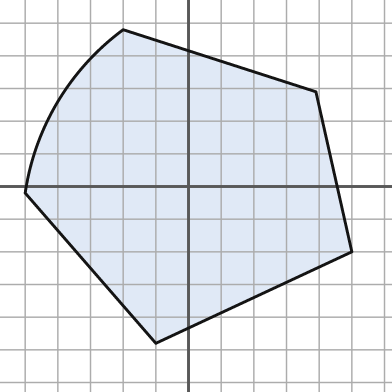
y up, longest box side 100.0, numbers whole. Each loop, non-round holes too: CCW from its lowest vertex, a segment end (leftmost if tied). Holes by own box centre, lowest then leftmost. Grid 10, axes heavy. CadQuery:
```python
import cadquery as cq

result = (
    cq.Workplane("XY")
    .moveTo(-10.0, -48.0)
    .lineTo(50.0, -20.0)
    .lineTo(39.0, 29.0)
    .lineTo(-20.0, 48.0)
    .threePointArc((-40.0, 26.0), (-50.0, -2.0))
    .close()
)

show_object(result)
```